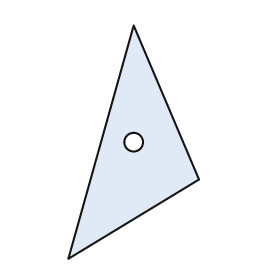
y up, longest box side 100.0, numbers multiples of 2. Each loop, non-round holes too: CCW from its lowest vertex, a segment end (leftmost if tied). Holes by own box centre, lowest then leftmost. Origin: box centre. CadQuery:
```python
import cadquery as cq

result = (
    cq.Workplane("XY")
    .moveTo(-28.0, -50.0)
    .lineTo(28.0, -16.0)
    .lineTo(0.0, 50.0)
    .close()
    .moveTo(0.0, 0.0)
    .circle(4.0)
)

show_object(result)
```